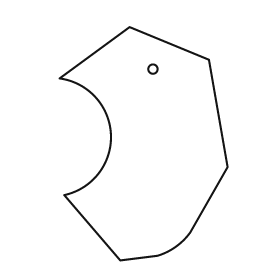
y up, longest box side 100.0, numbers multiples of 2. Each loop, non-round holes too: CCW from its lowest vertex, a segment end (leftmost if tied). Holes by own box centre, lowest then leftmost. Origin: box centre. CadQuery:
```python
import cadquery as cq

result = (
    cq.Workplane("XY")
    .moveTo(-10.0, -50.0)
    .lineTo(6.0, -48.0)
    .threePointArc((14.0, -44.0), (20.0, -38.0))
    .lineTo(36.0, -10.0)
    .lineTo(28.0, 36.0)
    .lineTo(-6.0, 50.0)
    .lineTo(-36.0, 28.0)
    .threePointArc((-14.0, 4.0), (-34.0, -22.0))
    .close()
    .moveTo(4.0, 32.0)
    .circle(2.0)
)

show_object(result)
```